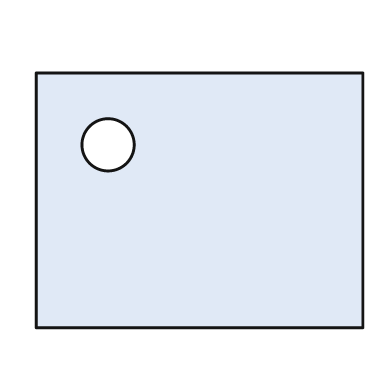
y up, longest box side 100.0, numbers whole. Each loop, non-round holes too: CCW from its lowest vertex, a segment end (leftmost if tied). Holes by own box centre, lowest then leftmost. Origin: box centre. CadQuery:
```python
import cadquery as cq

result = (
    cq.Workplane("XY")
    .moveTo(-50.0, -39.0)
    .lineTo(50.0, -39.0)
    .lineTo(50.0, 39.0)
    .lineTo(-50.0, 39.0)
    .close()
    .moveTo(-28.0, 17.0)
    .circle(8.0)
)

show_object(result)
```